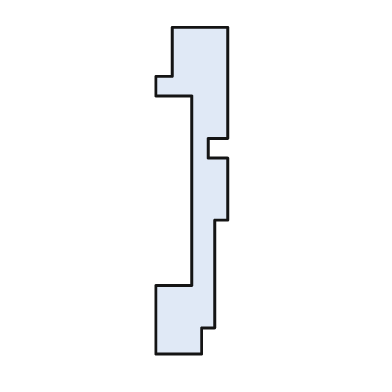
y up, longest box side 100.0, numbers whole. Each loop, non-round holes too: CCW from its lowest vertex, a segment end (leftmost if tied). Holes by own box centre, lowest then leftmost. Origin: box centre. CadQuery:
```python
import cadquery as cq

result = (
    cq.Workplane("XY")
    .moveTo(-11.0, -50.0)
    .lineTo(3.0, -50.0)
    .lineTo(3.0, -42.0)
    .lineTo(7.0, -42.0)
    .lineTo(7.0, -9.0)
    .lineTo(11.0, -9.0)
    .lineTo(11.0, 10.0)
    .lineTo(5.0, 10.0)
    .lineTo(5.0, 16.0)
    .lineTo(11.0, 16.0)
    .lineTo(11.0, 50.0)
    .lineTo(-6.0, 50.0)
    .lineTo(-6.0, 35.0)
    .lineTo(-11.0, 35.0)
    .lineTo(-11.0, 29.0)
    .lineTo(0.0, 29.0)
    .lineTo(0.0, -29.0)
    .lineTo(-11.0, -29.0)
    .close()
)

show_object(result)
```